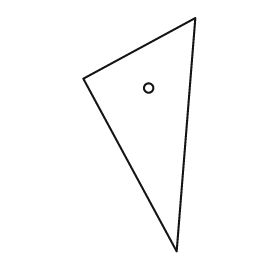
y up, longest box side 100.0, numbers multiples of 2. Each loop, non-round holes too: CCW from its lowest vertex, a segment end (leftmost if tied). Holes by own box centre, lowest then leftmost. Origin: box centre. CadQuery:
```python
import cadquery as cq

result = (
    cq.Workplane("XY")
    .moveTo(16.0, -50.0)
    .lineTo(24.0, 50.0)
    .lineTo(-24.0, 24.0)
    .close()
    .moveTo(4.0, 20.0)
    .circle(2.0)
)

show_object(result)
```